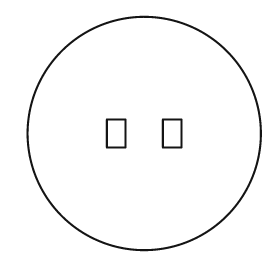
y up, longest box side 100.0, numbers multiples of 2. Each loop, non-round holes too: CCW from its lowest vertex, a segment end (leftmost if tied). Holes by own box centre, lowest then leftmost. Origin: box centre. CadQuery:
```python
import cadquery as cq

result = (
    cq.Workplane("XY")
    .moveTo(0.0, 0.0)
    .circle(50.0)
    .moveTo(-16.0, -6.0)
    .lineTo(-8.0, -6.0)
    .lineTo(-8.0, 6.0)
    .lineTo(-16.0, 6.0)
    .close()
    .moveTo(8.0, -6.0)
    .lineTo(16.0, -6.0)
    .lineTo(16.0, 6.0)
    .lineTo(8.0, 6.0)
    .close()
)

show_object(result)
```